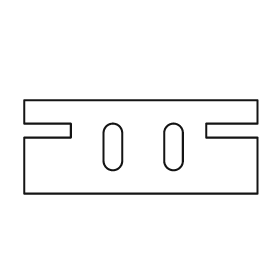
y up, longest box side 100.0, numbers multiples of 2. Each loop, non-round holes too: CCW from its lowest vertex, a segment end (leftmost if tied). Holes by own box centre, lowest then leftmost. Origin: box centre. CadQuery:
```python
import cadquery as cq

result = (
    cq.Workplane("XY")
    .moveTo(-50.0, -20.0)
    .lineTo(50.0, -20.0)
    .lineTo(50.0, 4.0)
    .lineTo(28.0, 4.0)
    .lineTo(28.0, 10.0)
    .lineTo(50.0, 10.0)
    .lineTo(50.0, 20.0)
    .lineTo(-50.0, 20.0)
    .lineTo(-50.0, 10.0)
    .lineTo(-30.0, 10.0)
    .lineTo(-30.0, 4.0)
    .lineTo(-50.0, 4.0)
    .close()
    .moveTo(-16.0, -6.0)
    .threePointArc((-12.0, -10.0), (-8.0, -6.0))
    .lineTo(-8.0, 6.0)
    .threePointArc((-12.0, 10.0), (-16.0, 6.0))
    .close()
    .moveTo(10.0, -6.0)
    .threePointArc((14.0, -10.0), (18.0, -6.0))
    .lineTo(18.0, 6.0)
    .threePointArc((14.0, 10.0), (10.0, 6.0))
    .close()
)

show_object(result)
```